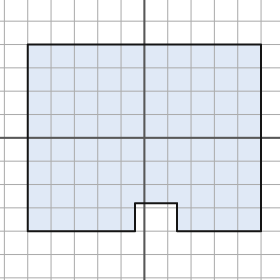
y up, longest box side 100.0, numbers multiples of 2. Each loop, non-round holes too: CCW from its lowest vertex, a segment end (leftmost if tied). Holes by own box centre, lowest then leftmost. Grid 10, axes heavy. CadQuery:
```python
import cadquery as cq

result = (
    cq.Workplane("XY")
    .moveTo(-50.0, -40.0)
    .lineTo(-4.0, -40.0)
    .lineTo(-4.0, -28.0)
    .lineTo(14.0, -28.0)
    .lineTo(14.0, -40.0)
    .lineTo(50.0, -40.0)
    .lineTo(50.0, 40.0)
    .lineTo(-50.0, 40.0)
    .close()
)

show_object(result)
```